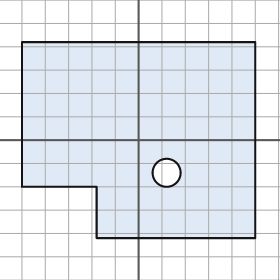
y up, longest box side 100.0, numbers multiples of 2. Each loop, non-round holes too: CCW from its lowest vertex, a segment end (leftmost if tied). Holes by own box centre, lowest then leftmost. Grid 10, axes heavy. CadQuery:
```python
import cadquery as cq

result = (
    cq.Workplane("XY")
    .moveTo(-18.0, -42.0)
    .lineTo(50.0, -42.0)
    .lineTo(50.0, 42.0)
    .lineTo(-50.0, 42.0)
    .lineTo(-50.0, -20.0)
    .lineTo(-18.0, -20.0)
    .close()
    .moveTo(12.0, -14.0)
    .circle(6.0)
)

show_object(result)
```